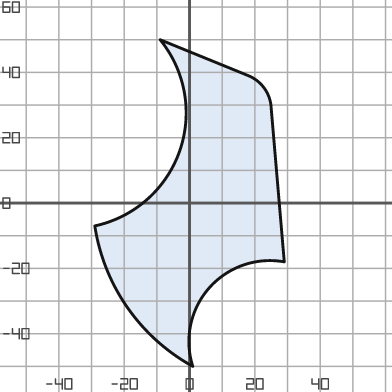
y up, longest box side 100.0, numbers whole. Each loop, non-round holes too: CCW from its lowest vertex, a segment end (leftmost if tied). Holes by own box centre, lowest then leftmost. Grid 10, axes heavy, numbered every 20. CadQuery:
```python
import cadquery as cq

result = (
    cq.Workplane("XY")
    .moveTo(1.0, -50.0)
    .threePointArc((6.0, -26.0), (29.0, -18.0))
    .lineTo(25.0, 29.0)
    .threePointArc((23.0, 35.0), (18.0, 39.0))
    .lineTo(-9.0, 50.0)
    .threePointArc((-3.0, 16.0), (-29.0, -7.0))
    .threePointArc((-19.0, -32.0), (1.0, -50.0))
    .close()
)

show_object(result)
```